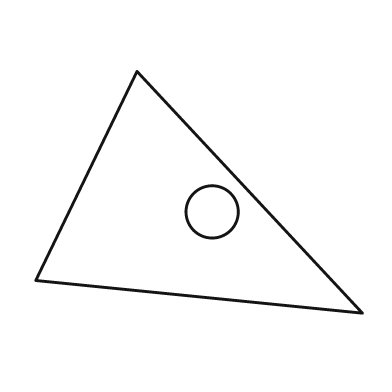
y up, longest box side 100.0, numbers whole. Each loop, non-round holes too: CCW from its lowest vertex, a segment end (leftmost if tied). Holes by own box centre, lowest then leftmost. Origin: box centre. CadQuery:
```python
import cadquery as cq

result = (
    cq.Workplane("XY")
    .moveTo(50.0, -37.0)
    .lineTo(-19.0, 37.0)
    .lineTo(-50.0, -27.0)
    .close()
    .moveTo(4.0, -6.0)
    .circle(8.0)
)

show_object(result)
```